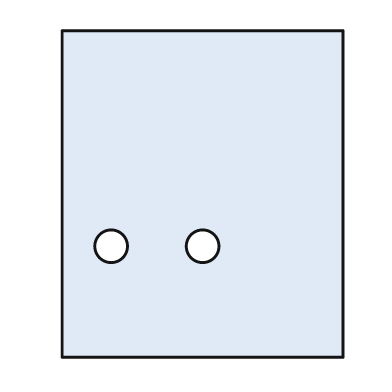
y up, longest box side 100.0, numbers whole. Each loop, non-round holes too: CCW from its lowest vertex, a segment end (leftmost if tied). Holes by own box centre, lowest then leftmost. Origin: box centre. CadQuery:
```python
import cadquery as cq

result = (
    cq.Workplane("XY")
    .moveTo(-43.0, -50.0)
    .lineTo(43.0, -50.0)
    .lineTo(43.0, 50.0)
    .lineTo(-43.0, 50.0)
    .close()
    .moveTo(-28.0, -16.0)
    .circle(5.0)
    .moveTo(0.0, -16.0)
    .circle(5.0)
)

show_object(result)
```